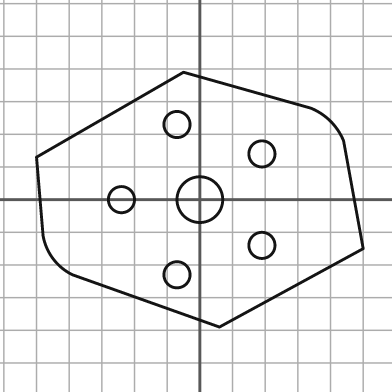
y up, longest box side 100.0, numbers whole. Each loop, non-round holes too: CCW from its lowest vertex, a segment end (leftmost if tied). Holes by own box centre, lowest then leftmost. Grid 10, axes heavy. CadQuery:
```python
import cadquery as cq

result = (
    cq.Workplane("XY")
    .moveTo(6.0, -39.0)
    .lineTo(50.0, -15.0)
    .lineTo(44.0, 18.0)
    .threePointArc((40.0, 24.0), (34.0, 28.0))
    .lineTo(-5.0, 39.0)
    .lineTo(-50.0, 13.0)
    .lineTo(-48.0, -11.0)
    .threePointArc((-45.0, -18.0), (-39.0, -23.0))
    .close()
    .moveTo(-7.0, -23.0)
    .circle(4.0)
    .moveTo(19.0, -14.0)
    .circle(4.0)
    .moveTo(-24.0, 0.0)
    .circle(4.0)
    .moveTo(0.0, 0.0)
    .circle(7.0)
    .moveTo(19.0, 14.0)
    .circle(4.0)
    .moveTo(-7.0, 23.0)
    .circle(4.0)
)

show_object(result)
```